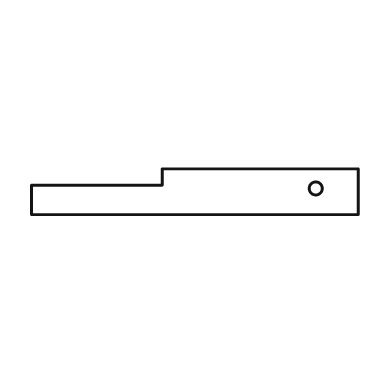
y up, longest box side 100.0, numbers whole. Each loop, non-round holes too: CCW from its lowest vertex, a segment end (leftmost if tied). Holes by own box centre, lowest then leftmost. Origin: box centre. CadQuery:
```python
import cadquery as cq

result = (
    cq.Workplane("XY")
    .moveTo(-50.0, -7.0)
    .lineTo(50.0, -7.0)
    .lineTo(50.0, 7.0)
    .lineTo(-10.0, 7.0)
    .lineTo(-10.0, 2.0)
    .lineTo(-50.0, 2.0)
    .close()
    .moveTo(37.0, 1.0)
    .circle(2.0)
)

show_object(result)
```